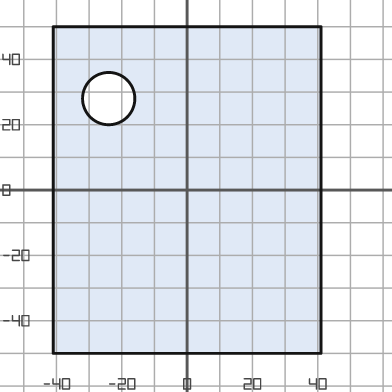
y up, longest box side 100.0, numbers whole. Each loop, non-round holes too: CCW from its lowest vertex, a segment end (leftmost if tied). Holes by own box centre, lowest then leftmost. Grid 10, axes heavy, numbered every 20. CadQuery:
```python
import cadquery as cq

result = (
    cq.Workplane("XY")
    .moveTo(-41.0, -50.0)
    .lineTo(41.0, -50.0)
    .lineTo(41.0, 50.0)
    .lineTo(-41.0, 50.0)
    .close()
    .moveTo(-24.0, 28.0)
    .circle(8.0)
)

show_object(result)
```